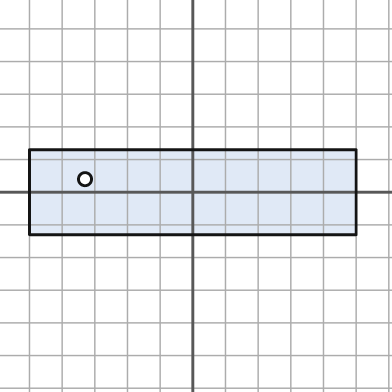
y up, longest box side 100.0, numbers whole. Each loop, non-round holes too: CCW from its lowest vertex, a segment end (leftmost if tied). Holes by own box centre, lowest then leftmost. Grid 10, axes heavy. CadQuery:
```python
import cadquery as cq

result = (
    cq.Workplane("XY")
    .moveTo(-50.0, -13.0)
    .lineTo(50.0, -13.0)
    .lineTo(50.0, 13.0)
    .lineTo(-50.0, 13.0)
    .close()
    .moveTo(-33.0, 4.0)
    .circle(2.0)
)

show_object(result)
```